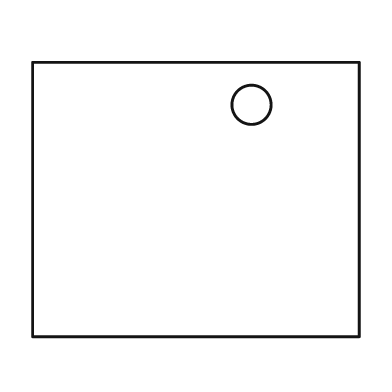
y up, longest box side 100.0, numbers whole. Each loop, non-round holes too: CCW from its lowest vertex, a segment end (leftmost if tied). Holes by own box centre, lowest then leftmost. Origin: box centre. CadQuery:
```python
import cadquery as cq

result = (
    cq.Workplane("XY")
    .moveTo(-50.0, -42.0)
    .lineTo(50.0, -42.0)
    .lineTo(50.0, 42.0)
    .lineTo(-50.0, 42.0)
    .close()
    .moveTo(17.0, 29.0)
    .circle(6.0)
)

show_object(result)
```